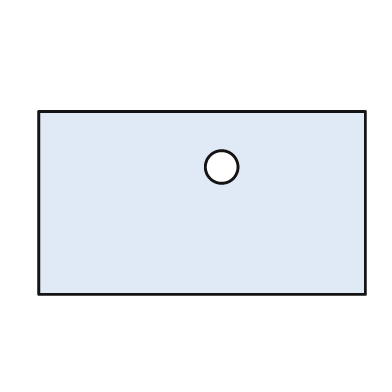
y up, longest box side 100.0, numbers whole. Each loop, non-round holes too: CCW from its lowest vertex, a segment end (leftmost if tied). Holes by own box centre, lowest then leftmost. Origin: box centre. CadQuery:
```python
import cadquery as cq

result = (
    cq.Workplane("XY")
    .moveTo(-50.0, -28.0)
    .lineTo(50.0, -28.0)
    .lineTo(50.0, 28.0)
    .lineTo(-50.0, 28.0)
    .close()
    .moveTo(6.0, 11.0)
    .circle(5.0)
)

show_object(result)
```